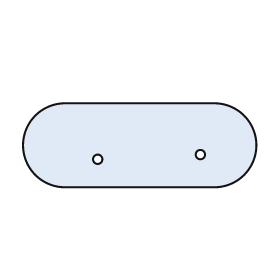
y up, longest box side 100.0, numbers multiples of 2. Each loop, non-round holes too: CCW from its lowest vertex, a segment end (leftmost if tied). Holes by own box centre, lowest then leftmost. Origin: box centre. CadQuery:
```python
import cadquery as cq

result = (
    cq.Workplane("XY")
    .moveTo(-32.0, -18.0)
    .lineTo(32.0, -18.0)
    .threePointArc((50.0, 0.0), (32.0, 18.0))
    .lineTo(-32.0, 18.0)
    .threePointArc((-50.0, 0.0), (-32.0, -18.0))
    .close()
    .moveTo(-18.0, -6.0)
    .circle(2.0)
    .moveTo(26.0, -4.0)
    .circle(2.0)
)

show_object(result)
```